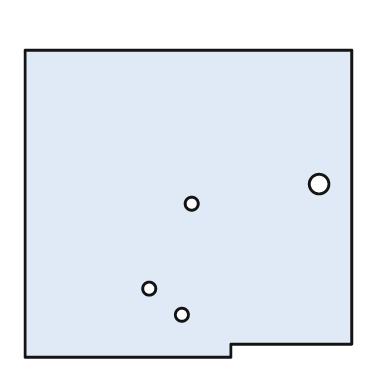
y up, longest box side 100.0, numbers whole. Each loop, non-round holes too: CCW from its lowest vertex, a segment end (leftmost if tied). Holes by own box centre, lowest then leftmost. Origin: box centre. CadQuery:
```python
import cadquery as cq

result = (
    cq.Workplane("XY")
    .moveTo(-50.0, -47.0)
    .lineTo(13.0, -47.0)
    .lineTo(13.0, -43.0)
    .lineTo(50.0, -43.0)
    .lineTo(50.0, 47.0)
    .lineTo(-50.0, 47.0)
    .close()
    .moveTo(-2.0, -34.0)
    .circle(2.0)
    .moveTo(-12.0, -26.0)
    .circle(2.0)
    .moveTo(1.0, 0.0)
    .circle(2.0)
    .moveTo(40.0, 6.0)
    .circle(3.0)
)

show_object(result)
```